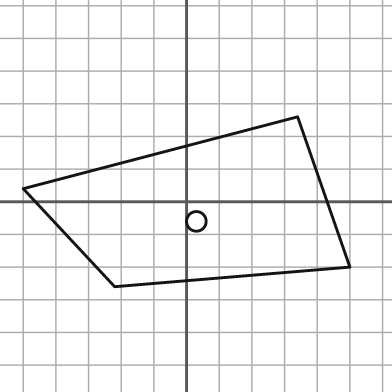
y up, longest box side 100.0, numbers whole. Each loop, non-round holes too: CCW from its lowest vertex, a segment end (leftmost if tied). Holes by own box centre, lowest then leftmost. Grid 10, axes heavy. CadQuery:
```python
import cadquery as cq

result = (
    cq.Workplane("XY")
    .moveTo(-22.0, -26.0)
    .lineTo(50.0, -20.0)
    .lineTo(34.0, 26.0)
    .lineTo(-50.0, 4.0)
    .close()
    .moveTo(3.0, -6.0)
    .circle(3.0)
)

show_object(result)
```